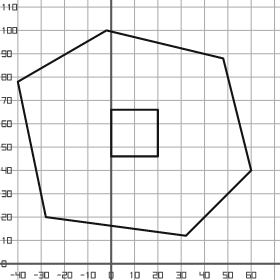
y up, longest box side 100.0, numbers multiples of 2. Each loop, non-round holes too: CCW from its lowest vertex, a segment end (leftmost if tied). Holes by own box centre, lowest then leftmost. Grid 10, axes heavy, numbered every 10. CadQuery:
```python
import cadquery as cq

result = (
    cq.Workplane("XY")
    .moveTo(32.0, 12.0)
    .lineTo(60.0, 40.0)
    .lineTo(48.0, 88.0)
    .lineTo(-2.0, 100.0)
    .lineTo(-40.0, 78.0)
    .lineTo(-28.0, 20.0)
    .close()
    .moveTo(0.0, 46.0)
    .lineTo(20.0, 46.0)
    .lineTo(20.0, 66.0)
    .lineTo(0.0, 66.0)
    .close()
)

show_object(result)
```